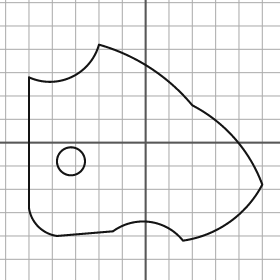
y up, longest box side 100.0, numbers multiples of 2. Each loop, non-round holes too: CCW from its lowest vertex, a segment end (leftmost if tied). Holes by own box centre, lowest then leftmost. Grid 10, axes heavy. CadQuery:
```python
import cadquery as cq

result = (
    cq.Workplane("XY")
    .moveTo(16.0, -42.0)
    .threePointArc((36.0, -34.0), (50.0, -18.0))
    .threePointArc((38.0, 2.0), (20.0, 16.0))
    .threePointArc((2.0, 32.0), (-20.0, 42.0))
    .threePointArc((-32.0, 28.0), (-50.0, 28.0))
    .lineTo(-50.0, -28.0)
    .threePointArc((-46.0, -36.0), (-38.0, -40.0))
    .lineTo(-14.0, -38.0)
    .threePointArc((2.0, -34.0), (16.0, -42.0))
    .close()
    .moveTo(-32.0, -8.0)
    .circle(6.0)
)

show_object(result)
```